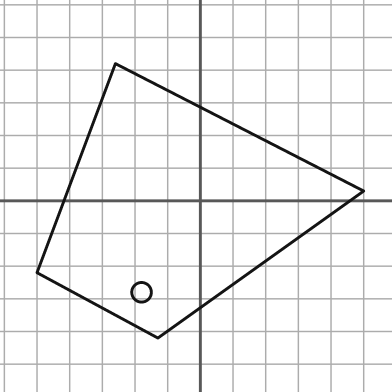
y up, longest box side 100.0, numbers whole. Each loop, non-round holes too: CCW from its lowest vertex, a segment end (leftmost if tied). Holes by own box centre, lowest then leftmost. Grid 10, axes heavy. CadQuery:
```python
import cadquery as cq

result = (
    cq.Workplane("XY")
    .moveTo(-13.0, -42.0)
    .lineTo(50.0, 3.0)
    .lineTo(-26.0, 42.0)
    .lineTo(-50.0, -22.0)
    .close()
    .moveTo(-18.0, -28.0)
    .circle(3.0)
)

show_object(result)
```